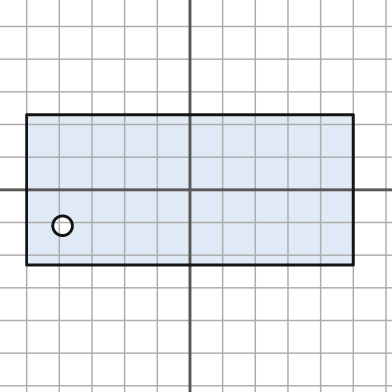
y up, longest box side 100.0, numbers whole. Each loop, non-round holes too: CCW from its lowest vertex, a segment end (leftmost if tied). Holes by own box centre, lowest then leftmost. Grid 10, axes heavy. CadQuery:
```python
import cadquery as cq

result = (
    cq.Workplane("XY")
    .moveTo(-50.0, -23.0)
    .lineTo(50.0, -23.0)
    .lineTo(50.0, 23.0)
    .lineTo(-50.0, 23.0)
    .close()
    .moveTo(-39.0, -11.0)
    .circle(3.0)
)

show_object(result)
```